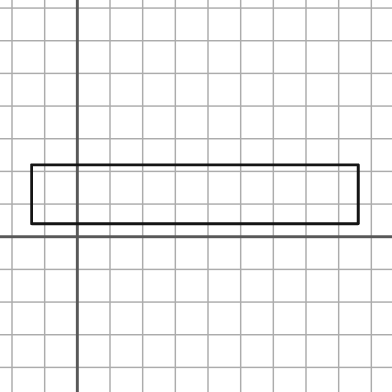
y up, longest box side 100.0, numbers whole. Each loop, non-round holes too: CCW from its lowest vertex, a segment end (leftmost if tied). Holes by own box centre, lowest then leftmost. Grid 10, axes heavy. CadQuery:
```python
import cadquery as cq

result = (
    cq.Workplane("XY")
    .moveTo(-14.0, 4.0)
    .lineTo(86.0, 4.0)
    .lineTo(86.0, 22.0)
    .lineTo(-14.0, 22.0)
    .close()
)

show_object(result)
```